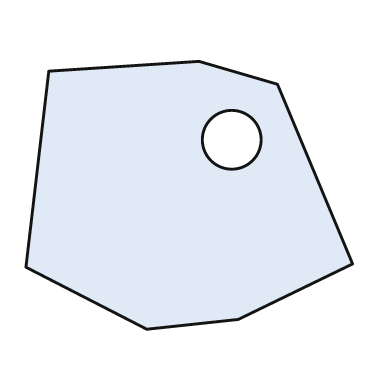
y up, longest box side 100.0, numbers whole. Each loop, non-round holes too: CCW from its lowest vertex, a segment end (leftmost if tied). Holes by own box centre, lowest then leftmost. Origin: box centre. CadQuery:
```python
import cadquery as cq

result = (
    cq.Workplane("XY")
    .moveTo(-13.0, -41.0)
    .lineTo(15.0, -38.0)
    .lineTo(50.0, -21.0)
    .lineTo(27.0, 34.0)
    .lineTo(3.0, 41.0)
    .lineTo(-43.0, 38.0)
    .lineTo(-50.0, -22.0)
    .close()
    .moveTo(13.0, 17.0)
    .circle(9.0)
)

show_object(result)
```